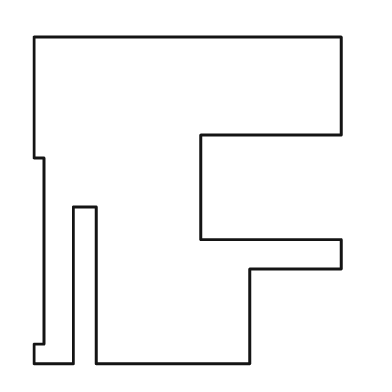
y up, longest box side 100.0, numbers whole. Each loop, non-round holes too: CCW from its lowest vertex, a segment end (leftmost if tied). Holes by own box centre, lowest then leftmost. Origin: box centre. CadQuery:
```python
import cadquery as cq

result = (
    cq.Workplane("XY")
    .moveTo(-47.0, -50.0)
    .lineTo(-35.0, -50.0)
    .lineTo(-35.0, -2.0)
    .lineTo(-28.0, -2.0)
    .lineTo(-28.0, -50.0)
    .lineTo(19.0, -50.0)
    .lineTo(19.0, -21.0)
    .lineTo(47.0, -21.0)
    .lineTo(47.0, -12.0)
    .lineTo(4.0, -12.0)
    .lineTo(4.0, 20.0)
    .lineTo(47.0, 20.0)
    .lineTo(47.0, 50.0)
    .lineTo(-47.0, 50.0)
    .lineTo(-47.0, 13.0)
    .lineTo(-44.0, 13.0)
    .lineTo(-44.0, -44.0)
    .lineTo(-47.0, -44.0)
    .close()
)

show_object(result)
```